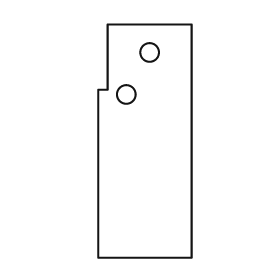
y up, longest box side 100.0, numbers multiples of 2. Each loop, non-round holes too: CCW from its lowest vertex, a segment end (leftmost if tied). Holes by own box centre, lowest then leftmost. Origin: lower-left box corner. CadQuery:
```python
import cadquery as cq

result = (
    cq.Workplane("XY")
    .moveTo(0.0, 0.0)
    .lineTo(40.0, 0.0)
    .lineTo(40.0, 100.0)
    .lineTo(4.0, 100.0)
    .lineTo(4.0, 72.0)
    .lineTo(0.0, 72.0)
    .close()
    .moveTo(12.0, 70.0)
    .circle(4.0)
    .moveTo(22.0, 88.0)
    .circle(4.0)
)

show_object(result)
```